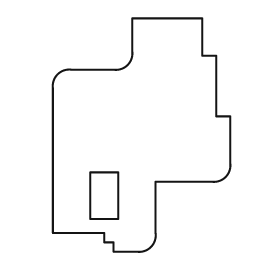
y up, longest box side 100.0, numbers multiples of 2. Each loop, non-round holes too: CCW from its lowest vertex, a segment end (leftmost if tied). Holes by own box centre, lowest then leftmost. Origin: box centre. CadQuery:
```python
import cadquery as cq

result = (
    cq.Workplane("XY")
    .moveTo(-12.0, -50.0)
    .lineTo(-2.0, -50.0)
    .threePointArc((4.0, -48.0), (6.0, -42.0))
    .lineTo(6.0, -20.0)
    .lineTo(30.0, -20.0)
    .threePointArc((36.0, -18.0), (38.0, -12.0))
    .lineTo(38.0, 8.0)
    .lineTo(32.0, 8.0)
    .lineTo(32.0, 34.0)
    .lineTo(26.0, 34.0)
    .lineTo(26.0, 50.0)
    .lineTo(-4.0, 50.0)
    .lineTo(-4.0, 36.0)
    .threePointArc((-6.0, 30.0), (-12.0, 28.0))
    .lineTo(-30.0, 28.0)
    .threePointArc((-36.0, 26.0), (-38.0, 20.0))
    .lineTo(-38.0, -42.0)
    .lineTo(-16.0, -42.0)
    .lineTo(-16.0, -46.0)
    .lineTo(-12.0, -46.0)
    .close()
    .moveTo(-22.0, -36.0)
    .lineTo(-10.0, -36.0)
    .lineTo(-10.0, -16.0)
    .lineTo(-22.0, -16.0)
    .close()
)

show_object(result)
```